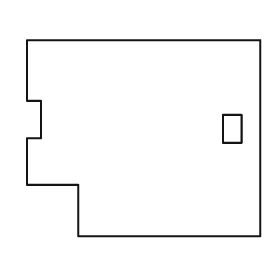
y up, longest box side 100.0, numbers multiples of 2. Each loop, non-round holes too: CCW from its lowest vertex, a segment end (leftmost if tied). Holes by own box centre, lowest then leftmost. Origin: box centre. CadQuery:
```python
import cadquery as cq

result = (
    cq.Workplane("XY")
    .moveTo(-28.0, -42.0)
    .lineTo(50.0, -42.0)
    .lineTo(50.0, 42.0)
    .lineTo(-50.0, 42.0)
    .lineTo(-50.0, 16.0)
    .lineTo(-44.0, 16.0)
    .lineTo(-44.0, 0.0)
    .lineTo(-50.0, 0.0)
    .lineTo(-50.0, -20.0)
    .lineTo(-28.0, -20.0)
    .close()
    .moveTo(34.0, -2.0)
    .lineTo(42.0, -2.0)
    .lineTo(42.0, 10.0)
    .lineTo(34.0, 10.0)
    .close()
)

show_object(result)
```